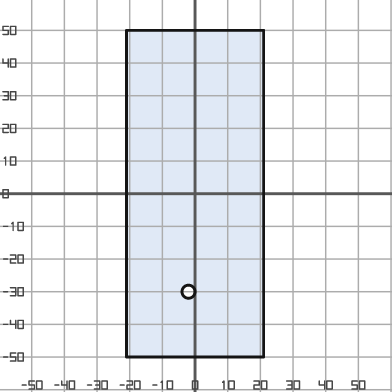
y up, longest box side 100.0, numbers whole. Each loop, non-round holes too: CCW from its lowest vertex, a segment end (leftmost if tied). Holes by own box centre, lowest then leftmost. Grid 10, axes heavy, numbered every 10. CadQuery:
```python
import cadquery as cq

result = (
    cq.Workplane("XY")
    .moveTo(-21.0, -50.0)
    .lineTo(21.0, -50.0)
    .lineTo(21.0, 50.0)
    .lineTo(-21.0, 50.0)
    .close()
    .moveTo(-2.0, -30.0)
    .circle(2.0)
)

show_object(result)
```